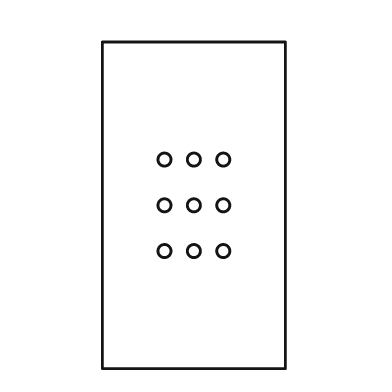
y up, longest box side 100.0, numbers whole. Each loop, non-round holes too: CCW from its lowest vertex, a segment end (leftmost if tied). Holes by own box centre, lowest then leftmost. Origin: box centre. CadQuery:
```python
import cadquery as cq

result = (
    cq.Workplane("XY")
    .moveTo(-28.0, -50.0)
    .lineTo(28.0, -50.0)
    .lineTo(28.0, 50.0)
    .lineTo(-28.0, 50.0)
    .close()
    .moveTo(-9.0, -14.0)
    .circle(2.0)
    .moveTo(0.0, -14.0)
    .circle(2.0)
    .moveTo(9.0, -14.0)
    .circle(2.0)
    .moveTo(-9.0, 0.0)
    .circle(2.0)
    .moveTo(0.0, 0.0)
    .circle(2.0)
    .moveTo(9.0, 0.0)
    .circle(2.0)
    .moveTo(-9.0, 14.0)
    .circle(2.0)
    .moveTo(0.0, 14.0)
    .circle(2.0)
    .moveTo(9.0, 14.0)
    .circle(2.0)
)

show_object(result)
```